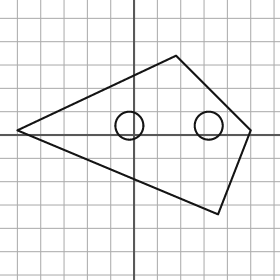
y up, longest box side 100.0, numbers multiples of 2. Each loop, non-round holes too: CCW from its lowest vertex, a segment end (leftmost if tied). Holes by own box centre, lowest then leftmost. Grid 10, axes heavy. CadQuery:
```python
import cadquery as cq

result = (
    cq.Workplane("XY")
    .moveTo(36.0, -34.0)
    .lineTo(50.0, 2.0)
    .lineTo(18.0, 34.0)
    .lineTo(-50.0, 2.0)
    .close()
    .moveTo(-2.0, 4.0)
    .circle(6.0)
    .moveTo(32.0, 4.0)
    .circle(6.0)
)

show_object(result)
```